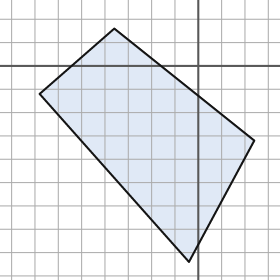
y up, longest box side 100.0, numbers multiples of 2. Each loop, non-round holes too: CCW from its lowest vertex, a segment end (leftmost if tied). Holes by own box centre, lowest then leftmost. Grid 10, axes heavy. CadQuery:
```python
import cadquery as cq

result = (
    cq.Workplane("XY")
    .moveTo(-4.0, -84.0)
    .lineTo(24.0, -32.0)
    .lineTo(-36.0, 16.0)
    .lineTo(-68.0, -12.0)
    .close()
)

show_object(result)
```